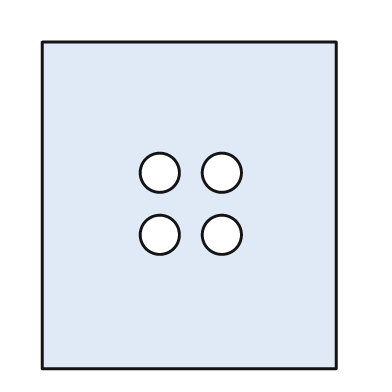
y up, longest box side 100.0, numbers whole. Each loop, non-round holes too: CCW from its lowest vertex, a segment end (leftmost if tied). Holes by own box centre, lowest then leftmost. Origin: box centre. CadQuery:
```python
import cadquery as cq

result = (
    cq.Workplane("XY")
    .moveTo(-45.0, -50.0)
    .lineTo(45.0, -50.0)
    .lineTo(45.0, 50.0)
    .lineTo(-45.0, 50.0)
    .close()
    .moveTo(-9.0, -9.0)
    .circle(6.0)
    .moveTo(10.0, -9.0)
    .circle(6.0)
    .moveTo(-9.0, 10.0)
    .circle(6.0)
    .moveTo(10.0, 10.0)
    .circle(6.0)
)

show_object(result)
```